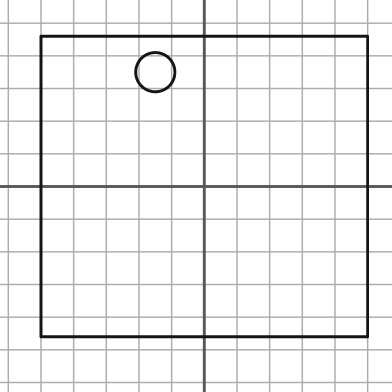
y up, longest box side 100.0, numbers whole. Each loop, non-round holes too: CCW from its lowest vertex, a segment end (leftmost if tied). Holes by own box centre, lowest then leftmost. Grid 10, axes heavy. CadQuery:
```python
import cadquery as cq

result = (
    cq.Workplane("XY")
    .moveTo(-50.0, -46.0)
    .lineTo(50.0, -46.0)
    .lineTo(50.0, 46.0)
    .lineTo(-50.0, 46.0)
    .close()
    .moveTo(-15.0, 35.0)
    .circle(6.0)
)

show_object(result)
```